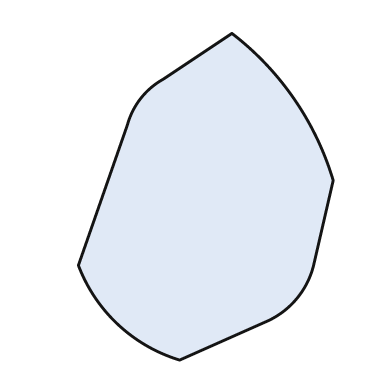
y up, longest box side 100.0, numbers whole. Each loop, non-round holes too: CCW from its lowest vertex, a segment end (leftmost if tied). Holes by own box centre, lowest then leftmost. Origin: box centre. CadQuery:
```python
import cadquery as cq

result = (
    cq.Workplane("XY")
    .moveTo(-8.0, -50.0)
    .lineTo(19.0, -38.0)
    .threePointArc((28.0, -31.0), (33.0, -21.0))
    .lineTo(39.0, 5.0)
    .threePointArc((27.0, 30.0), (8.0, 50.0))
    .lineTo(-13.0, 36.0)
    .threePointArc((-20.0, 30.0), (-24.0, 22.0))
    .lineTo(-39.0, -21.0)
    .threePointArc((-27.0, -39.0), (-8.0, -50.0))
    .close()
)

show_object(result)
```